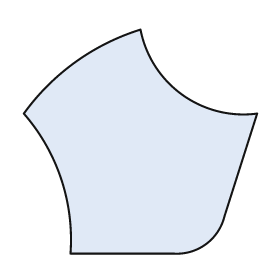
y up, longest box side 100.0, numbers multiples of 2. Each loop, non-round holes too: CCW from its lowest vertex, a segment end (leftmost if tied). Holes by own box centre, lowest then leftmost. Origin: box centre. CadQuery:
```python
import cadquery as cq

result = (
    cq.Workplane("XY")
    .moveTo(-30.0, -48.0)
    .lineTo(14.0, -48.0)
    .threePointArc((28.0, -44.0), (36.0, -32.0))
    .lineTo(50.0, 12.0)
    .threePointArc((18.0, 20.0), (0.0, 48.0))
    .threePointArc((-28.0, 34.0), (-50.0, 12.0))
    .threePointArc((-34.0, -16.0), (-30.0, -48.0))
    .close()
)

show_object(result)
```